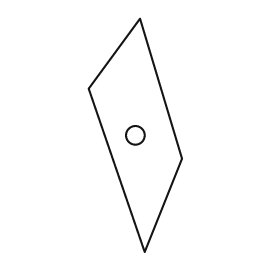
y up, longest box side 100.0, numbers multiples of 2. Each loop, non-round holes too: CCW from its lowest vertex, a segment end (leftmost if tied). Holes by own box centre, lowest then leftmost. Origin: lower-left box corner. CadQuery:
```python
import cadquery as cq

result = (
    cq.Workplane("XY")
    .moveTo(24.0, 0.0)
    .lineTo(40.0, 40.0)
    .lineTo(22.0, 100.0)
    .lineTo(0.0, 70.0)
    .close()
    .moveTo(20.0, 50.0)
    .circle(4.0)
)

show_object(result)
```